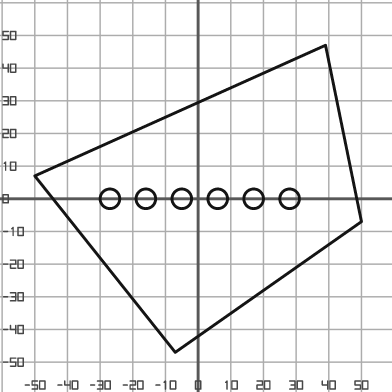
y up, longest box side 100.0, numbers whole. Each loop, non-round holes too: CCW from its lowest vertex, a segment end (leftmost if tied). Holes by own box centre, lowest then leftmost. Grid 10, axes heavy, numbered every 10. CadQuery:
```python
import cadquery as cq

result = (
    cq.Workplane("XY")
    .moveTo(-7.0, -47.0)
    .lineTo(50.0, -7.0)
    .lineTo(39.0, 47.0)
    .lineTo(-50.0, 7.0)
    .close()
    .moveTo(-27.0, 0.0)
    .circle(3.0)
    .moveTo(-16.0, 0.0)
    .circle(3.0)
    .moveTo(-5.0, 0.0)
    .circle(3.0)
    .moveTo(6.0, 0.0)
    .circle(3.0)
    .moveTo(17.0, 0.0)
    .circle(3.0)
    .moveTo(28.0, 0.0)
    .circle(3.0)
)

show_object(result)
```